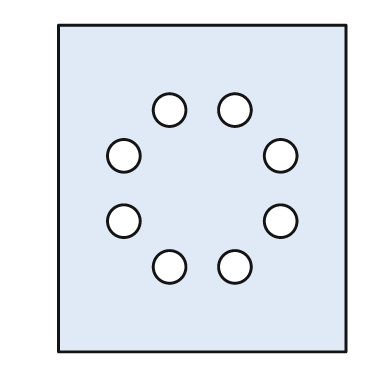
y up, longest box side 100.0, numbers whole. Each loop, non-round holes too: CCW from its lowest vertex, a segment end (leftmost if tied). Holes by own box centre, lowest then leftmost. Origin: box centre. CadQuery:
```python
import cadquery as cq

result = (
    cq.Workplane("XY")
    .moveTo(-44.0, -50.0)
    .lineTo(44.0, -50.0)
    .lineTo(44.0, 50.0)
    .lineTo(-44.0, 50.0)
    .close()
    .moveTo(-10.0, -24.0)
    .circle(5.0)
    .moveTo(10.0, -24.0)
    .circle(5.0)
    .moveTo(-24.0, -10.0)
    .circle(5.0)
    .moveTo(24.0, -10.0)
    .circle(5.0)
    .moveTo(-24.0, 10.0)
    .circle(5.0)
    .moveTo(24.0, 10.0)
    .circle(5.0)
    .moveTo(-10.0, 24.0)
    .circle(5.0)
    .moveTo(10.0, 24.0)
    .circle(5.0)
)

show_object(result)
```